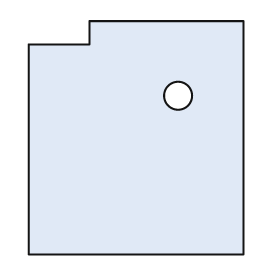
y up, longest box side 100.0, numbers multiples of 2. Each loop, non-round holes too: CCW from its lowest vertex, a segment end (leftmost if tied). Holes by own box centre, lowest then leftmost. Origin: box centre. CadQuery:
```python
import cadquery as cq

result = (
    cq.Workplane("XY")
    .moveTo(-46.0, -50.0)
    .lineTo(46.0, -50.0)
    .lineTo(46.0, 50.0)
    .lineTo(-20.0, 50.0)
    .lineTo(-20.0, 40.0)
    .lineTo(-46.0, 40.0)
    .close()
    .moveTo(18.0, 18.0)
    .circle(6.0)
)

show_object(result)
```